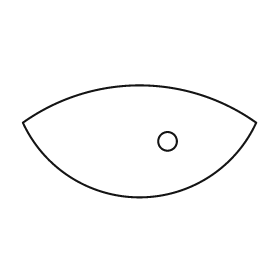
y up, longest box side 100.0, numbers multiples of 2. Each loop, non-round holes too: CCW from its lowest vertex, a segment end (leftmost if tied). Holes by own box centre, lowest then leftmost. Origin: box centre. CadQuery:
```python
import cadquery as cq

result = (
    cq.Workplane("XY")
    .moveTo(-50.0, 8.0)
    .threePointArc((0.0, -24.0), (50.0, 8.0))
    .threePointArc((0.0, 24.0), (-50.0, 8.0))
    .close()
    .moveTo(12.0, 0.0)
    .circle(4.0)
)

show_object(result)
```